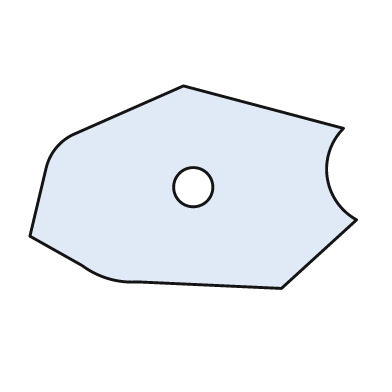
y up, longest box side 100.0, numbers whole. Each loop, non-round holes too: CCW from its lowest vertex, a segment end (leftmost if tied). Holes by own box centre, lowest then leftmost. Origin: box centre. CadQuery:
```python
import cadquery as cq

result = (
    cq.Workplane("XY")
    .moveTo(27.0, -31.0)
    .lineTo(50.0, -10.0)
    .threePointArc((41.0, 3.0), (46.0, 18.0))
    .lineTo(-3.0, 31.0)
    .lineTo(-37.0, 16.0)
    .threePointArc((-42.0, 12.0), (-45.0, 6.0))
    .lineTo(-50.0, -15.0)
    .lineTo(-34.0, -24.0)
    .threePointArc((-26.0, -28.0), (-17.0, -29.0))
    .close()
    .moveTo(0.0, 0.0)
    .circle(6.0)
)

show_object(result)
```